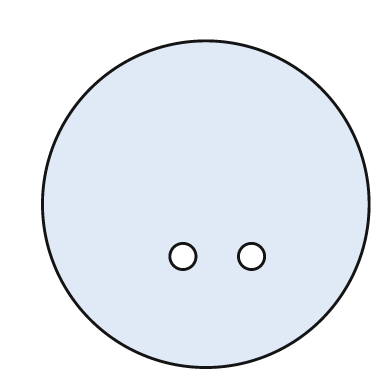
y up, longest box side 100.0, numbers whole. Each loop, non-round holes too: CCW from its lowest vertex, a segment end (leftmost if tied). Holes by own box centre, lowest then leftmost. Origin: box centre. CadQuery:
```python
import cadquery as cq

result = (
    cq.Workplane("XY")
    .moveTo(0.0, 0.0)
    .circle(50.0)
    .moveTo(-7.0, -16.0)
    .circle(4.0)
    .moveTo(14.0, -16.0)
    .circle(4.0)
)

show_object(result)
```